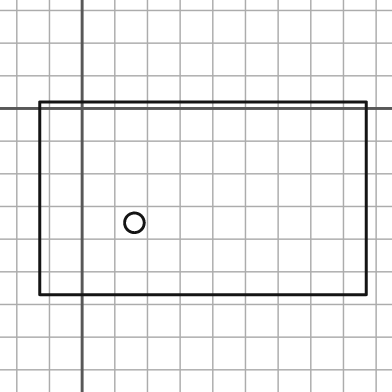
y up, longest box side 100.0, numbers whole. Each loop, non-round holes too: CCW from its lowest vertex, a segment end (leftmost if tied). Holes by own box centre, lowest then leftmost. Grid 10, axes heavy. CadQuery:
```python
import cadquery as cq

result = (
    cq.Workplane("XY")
    .moveTo(-13.0, -57.0)
    .lineTo(87.0, -57.0)
    .lineTo(87.0, 2.0)
    .lineTo(-13.0, 2.0)
    .close()
    .moveTo(16.0, -35.0)
    .circle(3.0)
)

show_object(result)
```